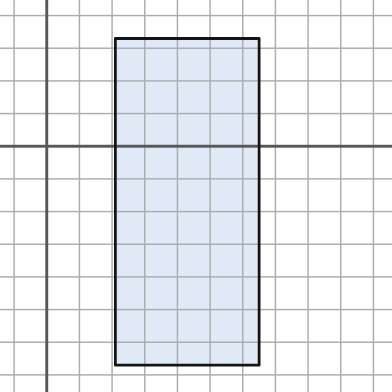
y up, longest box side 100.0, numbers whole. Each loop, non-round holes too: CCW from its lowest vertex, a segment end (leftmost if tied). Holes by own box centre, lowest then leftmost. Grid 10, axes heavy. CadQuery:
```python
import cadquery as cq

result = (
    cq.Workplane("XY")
    .moveTo(21.0, -67.0)
    .lineTo(65.0, -67.0)
    .lineTo(65.0, 33.0)
    .lineTo(21.0, 33.0)
    .close()
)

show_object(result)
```